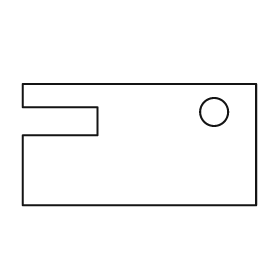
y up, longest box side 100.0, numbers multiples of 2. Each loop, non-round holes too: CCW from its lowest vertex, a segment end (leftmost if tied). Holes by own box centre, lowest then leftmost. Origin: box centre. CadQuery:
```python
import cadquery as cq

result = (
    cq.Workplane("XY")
    .moveTo(-50.0, -26.0)
    .lineTo(50.0, -26.0)
    .lineTo(50.0, 26.0)
    .lineTo(-50.0, 26.0)
    .lineTo(-50.0, 16.0)
    .lineTo(-18.0, 16.0)
    .lineTo(-18.0, 4.0)
    .lineTo(-50.0, 4.0)
    .close()
    .moveTo(32.0, 14.0)
    .circle(6.0)
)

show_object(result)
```